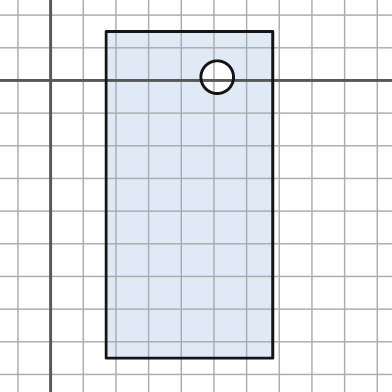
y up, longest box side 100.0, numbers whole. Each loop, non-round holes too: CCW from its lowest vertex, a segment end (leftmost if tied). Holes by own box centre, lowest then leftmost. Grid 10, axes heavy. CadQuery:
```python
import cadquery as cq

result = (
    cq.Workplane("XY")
    .moveTo(17.0, -85.0)
    .lineTo(68.0, -85.0)
    .lineTo(68.0, 15.0)
    .lineTo(17.0, 15.0)
    .close()
    .moveTo(51.0, 1.0)
    .circle(5.0)
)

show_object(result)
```